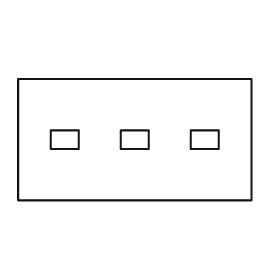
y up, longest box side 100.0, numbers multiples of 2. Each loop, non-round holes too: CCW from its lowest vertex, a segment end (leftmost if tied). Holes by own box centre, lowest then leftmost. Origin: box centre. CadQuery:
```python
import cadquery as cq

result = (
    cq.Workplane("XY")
    .moveTo(-50.0, -26.0)
    .lineTo(50.0, -26.0)
    .lineTo(50.0, 26.0)
    .lineTo(-50.0, 26.0)
    .close()
    .moveTo(-36.0, -4.0)
    .lineTo(-24.0, -4.0)
    .lineTo(-24.0, 4.0)
    .lineTo(-36.0, 4.0)
    .close()
    .moveTo(-6.0, -4.0)
    .lineTo(6.0, -4.0)
    .lineTo(6.0, 4.0)
    .lineTo(-6.0, 4.0)
    .close()
    .moveTo(24.0, -4.0)
    .lineTo(36.0, -4.0)
    .lineTo(36.0, 4.0)
    .lineTo(24.0, 4.0)
    .close()
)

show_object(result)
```